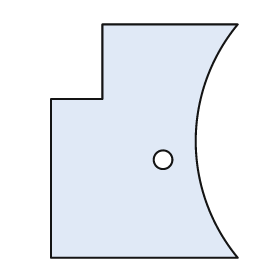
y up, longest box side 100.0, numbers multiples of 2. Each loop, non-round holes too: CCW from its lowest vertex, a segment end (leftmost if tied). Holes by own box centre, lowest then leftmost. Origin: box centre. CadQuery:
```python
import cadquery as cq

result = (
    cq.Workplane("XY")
    .moveTo(-40.0, -50.0)
    .lineTo(40.0, -50.0)
    .threePointArc((22.0, 0.0), (40.0, 50.0))
    .lineTo(-18.0, 50.0)
    .lineTo(-18.0, 18.0)
    .lineTo(-40.0, 18.0)
    .close()
    .moveTo(8.0, -8.0)
    .circle(4.0)
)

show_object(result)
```